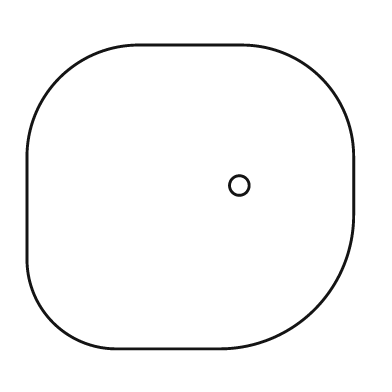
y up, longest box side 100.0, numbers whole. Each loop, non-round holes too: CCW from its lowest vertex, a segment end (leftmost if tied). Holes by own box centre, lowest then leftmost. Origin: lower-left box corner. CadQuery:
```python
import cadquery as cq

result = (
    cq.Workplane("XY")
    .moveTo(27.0, 0.0)
    .lineTo(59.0, 0.0)
    .threePointArc((88.0, 12.0), (100.0, 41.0))
    .lineTo(100.0, 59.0)
    .threePointArc((90.0, 83.0), (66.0, 93.0))
    .lineTo(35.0, 93.0)
    .threePointArc((10.0, 83.0), (0.0, 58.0))
    .lineTo(0.0, 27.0)
    .threePointArc((8.0, 8.0), (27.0, 0.0))
    .close()
    .moveTo(65.0, 50.0)
    .circle(3.0)
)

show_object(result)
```